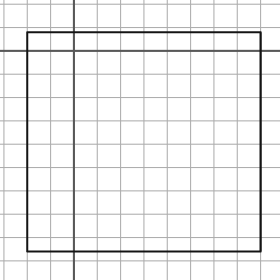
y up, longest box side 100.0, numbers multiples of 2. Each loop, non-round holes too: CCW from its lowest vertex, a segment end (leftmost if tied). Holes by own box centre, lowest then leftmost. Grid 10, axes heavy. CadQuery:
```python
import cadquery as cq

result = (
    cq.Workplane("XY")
    .moveTo(-20.0, -86.0)
    .lineTo(80.0, -86.0)
    .lineTo(80.0, 8.0)
    .lineTo(-20.0, 8.0)
    .close()
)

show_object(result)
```